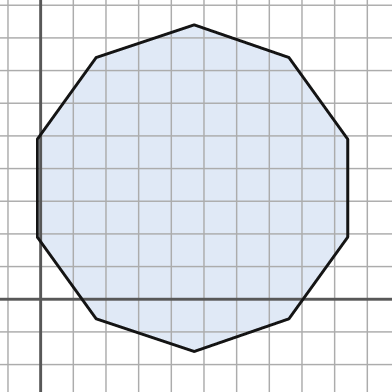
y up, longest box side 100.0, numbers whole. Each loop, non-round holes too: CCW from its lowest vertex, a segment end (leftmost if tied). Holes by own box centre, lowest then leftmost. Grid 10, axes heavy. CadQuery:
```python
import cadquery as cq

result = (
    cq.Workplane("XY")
    .moveTo(47.0, -16.0)
    .lineTo(76.0, -6.0)
    .lineTo(94.0, 19.0)
    .lineTo(94.0, 49.0)
    .lineTo(76.0, 74.0)
    .lineTo(47.0, 84.0)
    .lineTo(17.0, 74.0)
    .lineTo(-1.0, 49.0)
    .lineTo(-1.0, 19.0)
    .lineTo(17.0, -6.0)
    .close()
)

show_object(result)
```